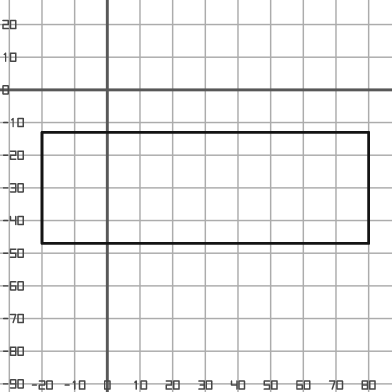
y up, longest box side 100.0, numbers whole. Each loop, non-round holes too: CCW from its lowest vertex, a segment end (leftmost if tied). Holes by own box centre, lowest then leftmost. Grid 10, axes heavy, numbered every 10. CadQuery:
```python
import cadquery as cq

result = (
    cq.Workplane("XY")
    .moveTo(-20.0, -47.0)
    .lineTo(80.0, -47.0)
    .lineTo(80.0, -13.0)
    .lineTo(-20.0, -13.0)
    .close()
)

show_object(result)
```